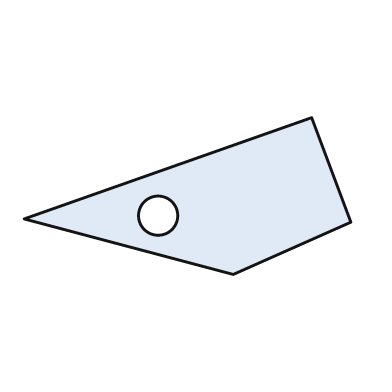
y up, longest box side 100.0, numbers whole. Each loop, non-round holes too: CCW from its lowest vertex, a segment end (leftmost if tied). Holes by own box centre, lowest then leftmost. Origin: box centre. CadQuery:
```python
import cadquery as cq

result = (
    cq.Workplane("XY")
    .moveTo(14.0, -24.0)
    .lineTo(50.0, -8.0)
    .lineTo(38.0, 24.0)
    .lineTo(-50.0, -7.0)
    .close()
    .moveTo(-9.0, -6.0)
    .circle(6.0)
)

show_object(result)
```